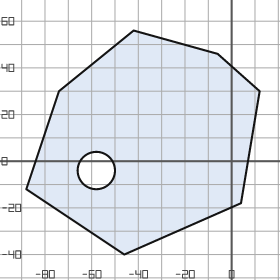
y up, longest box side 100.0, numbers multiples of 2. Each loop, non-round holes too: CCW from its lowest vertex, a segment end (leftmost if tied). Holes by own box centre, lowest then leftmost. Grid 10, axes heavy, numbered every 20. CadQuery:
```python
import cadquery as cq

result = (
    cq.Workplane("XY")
    .moveTo(-46.0, -40.0)
    .lineTo(4.0, -18.0)
    .lineTo(12.0, 30.0)
    .lineTo(-6.0, 46.0)
    .lineTo(-42.0, 56.0)
    .lineTo(-74.0, 30.0)
    .lineTo(-88.0, -12.0)
    .close()
    .moveTo(-58.0, -4.0)
    .circle(8.0)
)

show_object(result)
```